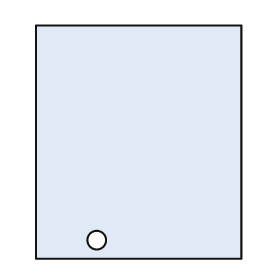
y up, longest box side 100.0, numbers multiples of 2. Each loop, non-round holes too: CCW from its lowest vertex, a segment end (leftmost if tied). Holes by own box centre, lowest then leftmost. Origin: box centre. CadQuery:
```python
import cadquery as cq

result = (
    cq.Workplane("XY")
    .moveTo(-44.0, -50.0)
    .lineTo(44.0, -50.0)
    .lineTo(44.0, 50.0)
    .lineTo(-44.0, 50.0)
    .close()
    .moveTo(-18.0, -42.0)
    .circle(4.0)
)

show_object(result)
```